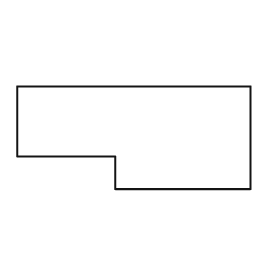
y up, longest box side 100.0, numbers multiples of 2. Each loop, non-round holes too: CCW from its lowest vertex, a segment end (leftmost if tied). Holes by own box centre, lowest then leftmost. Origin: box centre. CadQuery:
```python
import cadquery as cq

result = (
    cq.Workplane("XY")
    .moveTo(-8.0, -22.0)
    .lineTo(50.0, -22.0)
    .lineTo(50.0, 22.0)
    .lineTo(-50.0, 22.0)
    .lineTo(-50.0, -8.0)
    .lineTo(-8.0, -8.0)
    .close()
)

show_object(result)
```